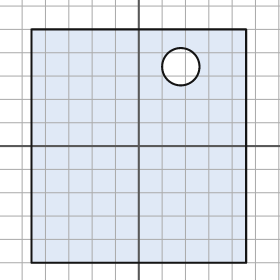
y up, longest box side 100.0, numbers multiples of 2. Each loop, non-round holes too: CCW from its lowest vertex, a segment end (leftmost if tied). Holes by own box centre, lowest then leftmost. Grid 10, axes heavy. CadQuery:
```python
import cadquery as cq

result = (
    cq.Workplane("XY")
    .moveTo(-46.0, -50.0)
    .lineTo(46.0, -50.0)
    .lineTo(46.0, 50.0)
    .lineTo(-46.0, 50.0)
    .close()
    .moveTo(18.0, 34.0)
    .circle(8.0)
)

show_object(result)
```